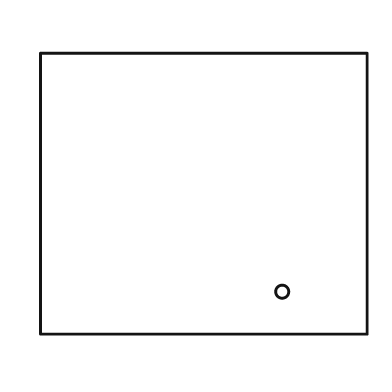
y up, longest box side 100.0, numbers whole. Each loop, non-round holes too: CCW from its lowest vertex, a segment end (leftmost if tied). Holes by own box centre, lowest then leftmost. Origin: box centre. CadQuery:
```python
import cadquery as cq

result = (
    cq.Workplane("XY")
    .moveTo(-50.0, -43.0)
    .lineTo(50.0, -43.0)
    .lineTo(50.0, 43.0)
    .lineTo(-50.0, 43.0)
    .close()
    .moveTo(24.0, -30.0)
    .circle(2.0)
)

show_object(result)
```